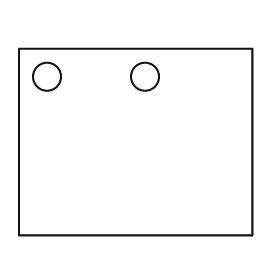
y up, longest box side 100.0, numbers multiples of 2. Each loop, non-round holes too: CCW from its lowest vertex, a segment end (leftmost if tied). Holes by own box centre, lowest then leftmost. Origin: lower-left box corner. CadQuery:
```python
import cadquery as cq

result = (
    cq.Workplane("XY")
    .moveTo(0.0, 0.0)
    .lineTo(100.0, 0.0)
    .lineTo(100.0, 80.0)
    .lineTo(0.0, 80.0)
    .close()
    .moveTo(12.0, 68.0)
    .circle(6.0)
    .moveTo(54.0, 68.0)
    .circle(6.0)
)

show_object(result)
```